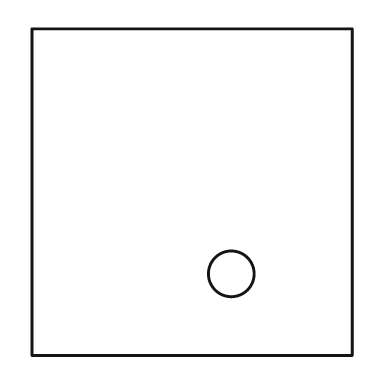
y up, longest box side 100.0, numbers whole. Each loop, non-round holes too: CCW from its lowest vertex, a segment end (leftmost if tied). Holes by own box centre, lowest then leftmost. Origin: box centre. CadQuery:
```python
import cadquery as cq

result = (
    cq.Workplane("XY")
    .moveTo(-49.0, -50.0)
    .lineTo(49.0, -50.0)
    .lineTo(49.0, 50.0)
    .lineTo(-49.0, 50.0)
    .close()
    .moveTo(12.0, -25.0)
    .circle(7.0)
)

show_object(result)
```